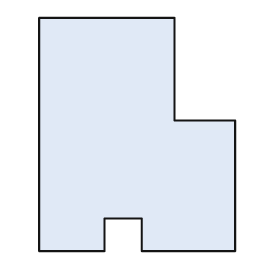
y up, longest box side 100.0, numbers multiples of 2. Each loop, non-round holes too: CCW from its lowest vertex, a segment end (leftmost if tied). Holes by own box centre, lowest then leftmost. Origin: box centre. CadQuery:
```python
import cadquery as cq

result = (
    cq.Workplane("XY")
    .moveTo(-42.0, -50.0)
    .lineTo(-14.0, -50.0)
    .lineTo(-14.0, -36.0)
    .lineTo(2.0, -36.0)
    .lineTo(2.0, -50.0)
    .lineTo(42.0, -50.0)
    .lineTo(42.0, 6.0)
    .lineTo(16.0, 6.0)
    .lineTo(16.0, 50.0)
    .lineTo(-42.0, 50.0)
    .close()
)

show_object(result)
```